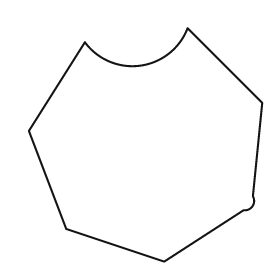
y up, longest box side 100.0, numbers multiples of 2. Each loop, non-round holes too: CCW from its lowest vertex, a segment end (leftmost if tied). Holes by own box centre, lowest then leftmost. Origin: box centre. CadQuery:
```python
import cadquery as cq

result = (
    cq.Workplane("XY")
    .moveTo(8.0, -50.0)
    .lineTo(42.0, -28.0)
    .threePointArc((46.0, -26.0), (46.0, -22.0))
    .lineTo(50.0, 18.0)
    .lineTo(18.0, 50.0)
    .threePointArc((-2.0, 34.0), (-26.0, 44.0))
    .lineTo(-50.0, 6.0)
    .lineTo(-34.0, -36.0)
    .close()
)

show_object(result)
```